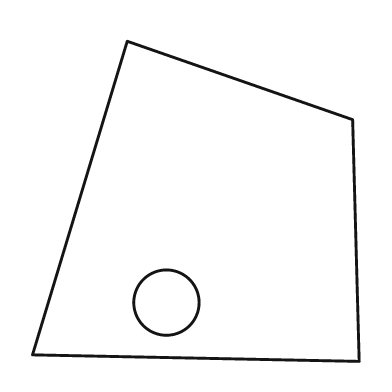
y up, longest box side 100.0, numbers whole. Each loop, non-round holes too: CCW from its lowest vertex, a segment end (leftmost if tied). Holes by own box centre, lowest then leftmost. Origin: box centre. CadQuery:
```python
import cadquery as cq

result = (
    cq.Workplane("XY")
    .moveTo(50.0, -49.0)
    .lineTo(48.0, 25.0)
    .lineTo(-21.0, 49.0)
    .lineTo(-50.0, -47.0)
    .close()
    .moveTo(-9.0, -31.0)
    .circle(10.0)
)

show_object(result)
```